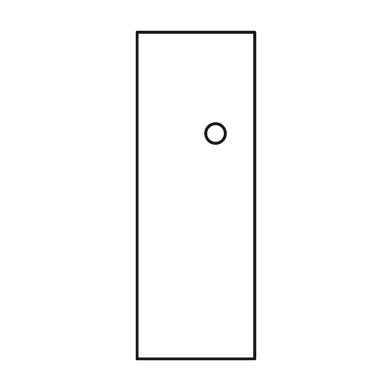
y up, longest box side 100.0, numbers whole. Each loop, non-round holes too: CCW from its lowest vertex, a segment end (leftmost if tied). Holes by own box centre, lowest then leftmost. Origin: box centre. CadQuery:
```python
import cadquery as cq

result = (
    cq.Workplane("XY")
    .moveTo(-18.0, -50.0)
    .lineTo(18.0, -50.0)
    .lineTo(18.0, 50.0)
    .lineTo(-18.0, 50.0)
    .close()
    .moveTo(6.0, 19.0)
    .circle(3.0)
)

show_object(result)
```